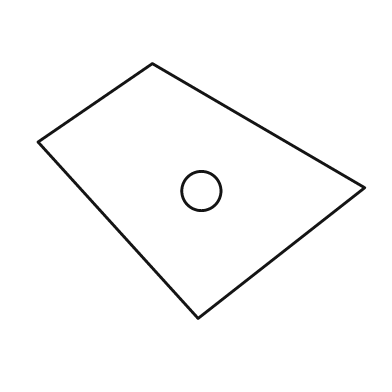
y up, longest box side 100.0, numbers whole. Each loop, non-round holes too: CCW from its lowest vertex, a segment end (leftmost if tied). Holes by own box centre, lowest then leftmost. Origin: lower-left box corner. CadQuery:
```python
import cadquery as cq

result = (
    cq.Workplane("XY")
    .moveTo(49.0, 0.0)
    .lineTo(100.0, 40.0)
    .lineTo(35.0, 78.0)
    .lineTo(0.0, 54.0)
    .close()
    .moveTo(50.0, 39.0)
    .circle(6.0)
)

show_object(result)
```